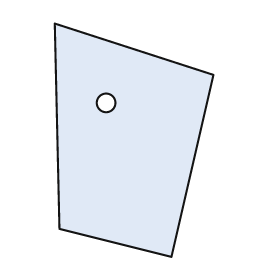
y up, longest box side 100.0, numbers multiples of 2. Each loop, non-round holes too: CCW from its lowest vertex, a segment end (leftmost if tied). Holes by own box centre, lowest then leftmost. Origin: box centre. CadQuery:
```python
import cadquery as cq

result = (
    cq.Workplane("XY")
    .moveTo(16.0, -50.0)
    .lineTo(34.0, 28.0)
    .lineTo(-34.0, 50.0)
    .lineTo(-32.0, -38.0)
    .close()
    .moveTo(-12.0, 16.0)
    .circle(4.0)
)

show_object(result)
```